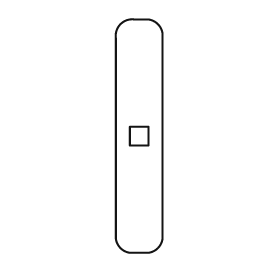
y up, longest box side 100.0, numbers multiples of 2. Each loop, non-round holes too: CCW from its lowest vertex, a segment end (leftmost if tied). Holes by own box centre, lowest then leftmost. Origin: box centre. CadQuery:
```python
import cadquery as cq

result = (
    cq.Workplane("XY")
    .moveTo(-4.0, -50.0)
    .lineTo(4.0, -50.0)
    .threePointArc((8.0, -48.0), (10.0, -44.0))
    .lineTo(10.0, 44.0)
    .threePointArc((8.0, 48.0), (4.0, 50.0))
    .lineTo(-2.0, 50.0)
    .threePointArc((-8.0, 48.0), (-10.0, 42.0))
    .lineTo(-10.0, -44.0)
    .threePointArc((-8.0, -48.0), (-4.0, -50.0))
    .close()
    .moveTo(-4.0, -4.0)
    .lineTo(4.0, -4.0)
    .lineTo(4.0, 4.0)
    .lineTo(-4.0, 4.0)
    .close()
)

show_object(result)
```